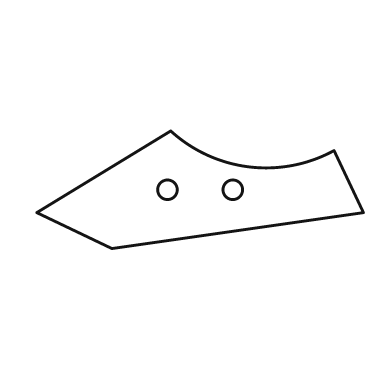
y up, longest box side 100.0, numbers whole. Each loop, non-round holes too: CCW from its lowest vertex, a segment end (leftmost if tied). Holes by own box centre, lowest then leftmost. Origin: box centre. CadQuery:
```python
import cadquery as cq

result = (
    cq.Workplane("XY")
    .moveTo(-27.0, -18.0)
    .lineTo(50.0, -7.0)
    .lineTo(41.0, 12.0)
    .threePointArc((15.0, 7.0), (-9.0, 18.0))
    .lineTo(-50.0, -7.0)
    .close()
    .moveTo(-10.0, 0.0)
    .circle(3.0)
    .moveTo(10.0, 0.0)
    .circle(3.0)
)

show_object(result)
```